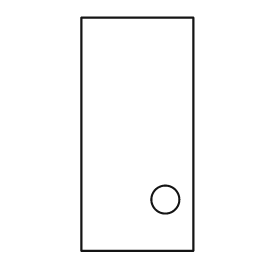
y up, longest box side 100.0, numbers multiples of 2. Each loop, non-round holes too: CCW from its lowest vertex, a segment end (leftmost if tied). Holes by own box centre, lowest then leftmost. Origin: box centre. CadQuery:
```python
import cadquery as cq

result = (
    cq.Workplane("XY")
    .moveTo(-24.0, -50.0)
    .lineTo(24.0, -50.0)
    .lineTo(24.0, 50.0)
    .lineTo(-24.0, 50.0)
    .close()
    .moveTo(12.0, -28.0)
    .circle(6.0)
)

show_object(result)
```